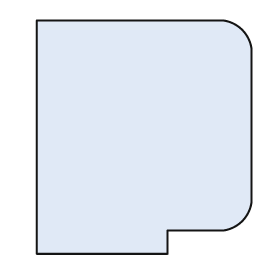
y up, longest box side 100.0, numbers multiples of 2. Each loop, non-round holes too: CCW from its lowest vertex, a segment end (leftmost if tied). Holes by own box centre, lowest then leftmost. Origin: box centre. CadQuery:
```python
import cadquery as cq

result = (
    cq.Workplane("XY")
    .moveTo(-46.0, -50.0)
    .lineTo(10.0, -50.0)
    .lineTo(10.0, -40.0)
    .lineTo(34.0, -40.0)
    .threePointArc((42.0, -36.0), (46.0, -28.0))
    .lineTo(46.0, 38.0)
    .threePointArc((42.0, 46.0), (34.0, 50.0))
    .lineTo(-46.0, 50.0)
    .close()
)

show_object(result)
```